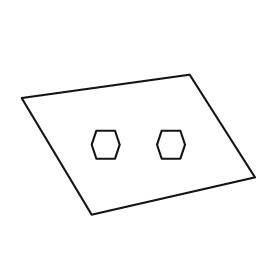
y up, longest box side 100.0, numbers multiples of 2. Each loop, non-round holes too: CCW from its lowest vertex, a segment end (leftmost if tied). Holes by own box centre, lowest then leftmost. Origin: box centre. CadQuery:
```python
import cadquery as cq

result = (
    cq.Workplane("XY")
    .moveTo(-20.0, -30.0)
    .lineTo(50.0, -14.0)
    .lineTo(22.0, 30.0)
    .lineTo(-50.0, 20.0)
    .close()
    .moveTo(-18.0, -6.0)
    .lineTo(-10.0, -6.0)
    .lineTo(-8.0, 0.0)
    .lineTo(-10.0, 6.0)
    .lineTo(-18.0, 6.0)
    .lineTo(-20.0, 0.0)
    .close()
    .moveTo(10.0, -6.0)
    .lineTo(18.0, -6.0)
    .lineTo(20.0, 0.0)
    .lineTo(18.0, 6.0)
    .lineTo(10.0, 6.0)
    .lineTo(8.0, 0.0)
    .close()
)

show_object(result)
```